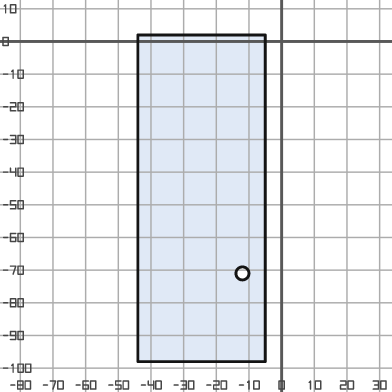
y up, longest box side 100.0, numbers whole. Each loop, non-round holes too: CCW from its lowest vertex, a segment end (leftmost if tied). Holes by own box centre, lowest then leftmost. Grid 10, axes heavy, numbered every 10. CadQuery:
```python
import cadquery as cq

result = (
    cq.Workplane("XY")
    .moveTo(-44.0, -98.0)
    .lineTo(-5.0, -98.0)
    .lineTo(-5.0, 2.0)
    .lineTo(-44.0, 2.0)
    .close()
    .moveTo(-12.0, -71.0)
    .circle(2.0)
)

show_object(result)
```